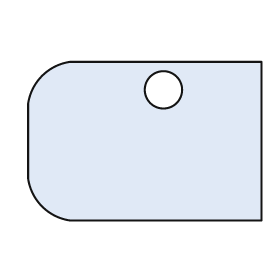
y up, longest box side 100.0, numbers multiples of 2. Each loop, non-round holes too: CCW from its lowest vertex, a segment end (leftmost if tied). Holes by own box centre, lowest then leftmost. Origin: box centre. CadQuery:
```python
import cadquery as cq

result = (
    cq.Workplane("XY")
    .moveTo(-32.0, -34.0)
    .lineTo(50.0, -34.0)
    .lineTo(50.0, 34.0)
    .lineTo(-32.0, 34.0)
    .threePointArc((-44.0, 28.0), (-50.0, 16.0))
    .lineTo(-50.0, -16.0)
    .threePointArc((-44.0, -28.0), (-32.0, -34.0))
    .close()
    .moveTo(8.0, 22.0)
    .circle(8.0)
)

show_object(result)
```